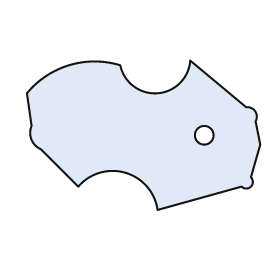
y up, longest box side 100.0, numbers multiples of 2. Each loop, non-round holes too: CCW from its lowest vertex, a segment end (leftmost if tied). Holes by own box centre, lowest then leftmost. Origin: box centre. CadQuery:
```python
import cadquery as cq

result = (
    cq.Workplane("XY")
    .moveTo(6.0, -32.0)
    .lineTo(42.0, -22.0)
    .threePointArc((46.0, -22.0), (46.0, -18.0))
    .lineTo(50.0, -4.0)
    .lineTo(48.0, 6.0)
    .threePointArc((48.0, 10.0), (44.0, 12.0))
    .lineTo(20.0, 32.0)
    .threePointArc((6.0, 18.0), (-10.0, 30.0))
    .threePointArc((-32.0, 30.0), (-50.0, 18.0))
    .lineTo(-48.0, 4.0)
    .threePointArc((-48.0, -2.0), (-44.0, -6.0))
    .lineTo(-28.0, -22.0)
    .threePointArc((-8.0, -16.0), (6.0, -32.0))
    .close()
    .moveTo(26.0, 0.0)
    .circle(4.0)
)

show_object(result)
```